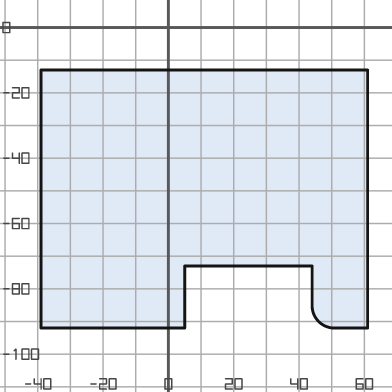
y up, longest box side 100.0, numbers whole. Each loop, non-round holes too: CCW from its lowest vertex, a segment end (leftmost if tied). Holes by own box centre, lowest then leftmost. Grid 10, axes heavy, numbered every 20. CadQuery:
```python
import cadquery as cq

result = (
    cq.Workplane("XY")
    .moveTo(-39.0, -92.0)
    .lineTo(5.0, -92.0)
    .lineTo(5.0, -73.0)
    .lineTo(44.0, -73.0)
    .lineTo(44.0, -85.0)
    .threePointArc((46.0, -90.0), (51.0, -92.0))
    .lineTo(61.0, -92.0)
    .lineTo(61.0, -13.0)
    .lineTo(-39.0, -13.0)
    .close()
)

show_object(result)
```